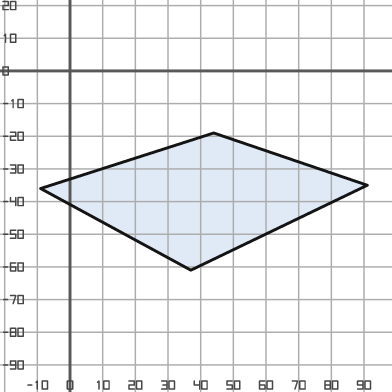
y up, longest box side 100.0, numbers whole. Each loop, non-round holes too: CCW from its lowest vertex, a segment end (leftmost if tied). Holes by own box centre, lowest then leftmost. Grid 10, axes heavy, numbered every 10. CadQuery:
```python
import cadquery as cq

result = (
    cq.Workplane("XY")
    .moveTo(37.0, -61.0)
    .lineTo(91.0, -35.0)
    .lineTo(44.0, -19.0)
    .lineTo(-9.0, -36.0)
    .close()
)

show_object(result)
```